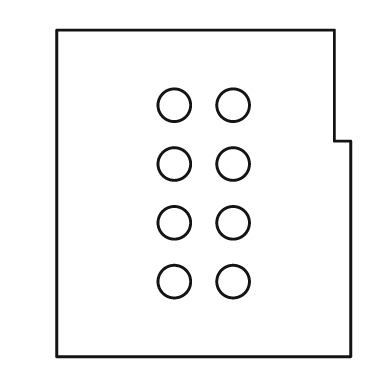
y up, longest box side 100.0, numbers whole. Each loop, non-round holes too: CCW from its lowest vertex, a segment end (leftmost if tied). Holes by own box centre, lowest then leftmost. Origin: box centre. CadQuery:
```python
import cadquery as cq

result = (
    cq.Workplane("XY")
    .moveTo(-45.0, -50.0)
    .lineTo(45.0, -50.0)
    .lineTo(45.0, 16.0)
    .lineTo(40.0, 16.0)
    .lineTo(40.0, 50.0)
    .lineTo(-45.0, 50.0)
    .close()
    .moveTo(-9.0, -27.0)
    .circle(5.0)
    .moveTo(9.0, -27.0)
    .circle(5.0)
    .moveTo(-9.0, -9.0)
    .circle(5.0)
    .moveTo(9.0, -9.0)
    .circle(5.0)
    .moveTo(-9.0, 9.0)
    .circle(5.0)
    .moveTo(9.0, 9.0)
    .circle(5.0)
    .moveTo(-9.0, 27.0)
    .circle(5.0)
    .moveTo(9.0, 27.0)
    .circle(5.0)
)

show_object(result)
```